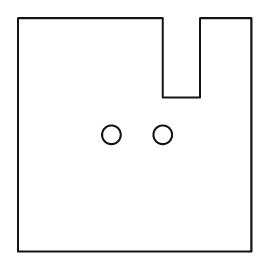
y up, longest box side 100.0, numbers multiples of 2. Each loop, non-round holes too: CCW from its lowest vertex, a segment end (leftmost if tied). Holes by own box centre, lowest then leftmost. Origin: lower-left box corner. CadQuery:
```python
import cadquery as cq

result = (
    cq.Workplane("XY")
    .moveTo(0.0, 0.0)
    .lineTo(100.0, 0.0)
    .lineTo(100.0, 100.0)
    .lineTo(78.0, 100.0)
    .lineTo(78.0, 66.0)
    .lineTo(62.0, 66.0)
    .lineTo(62.0, 100.0)
    .lineTo(0.0, 100.0)
    .close()
    .moveTo(40.0, 50.0)
    .circle(4.0)
    .moveTo(62.0, 50.0)
    .circle(4.0)
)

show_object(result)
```